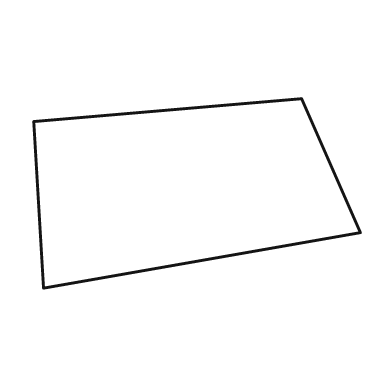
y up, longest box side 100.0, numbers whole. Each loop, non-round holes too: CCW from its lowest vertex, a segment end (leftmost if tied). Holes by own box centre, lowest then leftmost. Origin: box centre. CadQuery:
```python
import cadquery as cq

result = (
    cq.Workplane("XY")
    .moveTo(-47.0, -29.0)
    .lineTo(50.0, -12.0)
    .lineTo(32.0, 29.0)
    .lineTo(-50.0, 22.0)
    .close()
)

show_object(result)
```